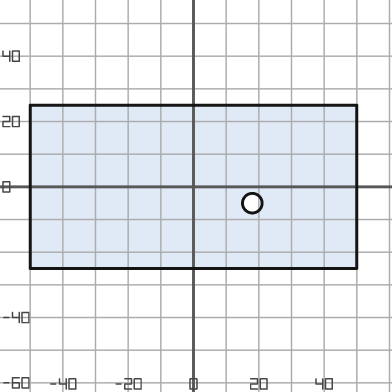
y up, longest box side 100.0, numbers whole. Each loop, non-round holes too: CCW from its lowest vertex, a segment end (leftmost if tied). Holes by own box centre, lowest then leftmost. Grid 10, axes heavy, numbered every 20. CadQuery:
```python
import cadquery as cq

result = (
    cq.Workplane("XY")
    .moveTo(-50.0, -25.0)
    .lineTo(50.0, -25.0)
    .lineTo(50.0, 25.0)
    .lineTo(-50.0, 25.0)
    .close()
    .moveTo(18.0, -5.0)
    .circle(3.0)
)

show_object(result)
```